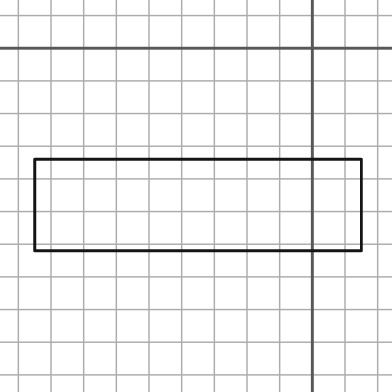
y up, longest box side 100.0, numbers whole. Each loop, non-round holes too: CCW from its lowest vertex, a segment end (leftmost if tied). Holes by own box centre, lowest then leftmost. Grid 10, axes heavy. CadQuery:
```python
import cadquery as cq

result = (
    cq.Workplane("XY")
    .moveTo(-85.0, -62.0)
    .lineTo(15.0, -62.0)
    .lineTo(15.0, -34.0)
    .lineTo(-85.0, -34.0)
    .close()
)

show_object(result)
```